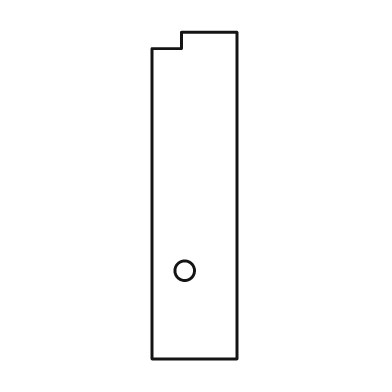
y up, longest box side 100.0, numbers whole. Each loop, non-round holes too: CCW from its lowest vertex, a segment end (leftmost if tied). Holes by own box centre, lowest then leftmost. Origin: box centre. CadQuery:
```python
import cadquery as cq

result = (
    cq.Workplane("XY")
    .moveTo(-13.0, -50.0)
    .lineTo(13.0, -50.0)
    .lineTo(13.0, 50.0)
    .lineTo(-4.0, 50.0)
    .lineTo(-4.0, 45.0)
    .lineTo(-13.0, 45.0)
    .close()
    .moveTo(-3.0, -23.0)
    .circle(3.0)
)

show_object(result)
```